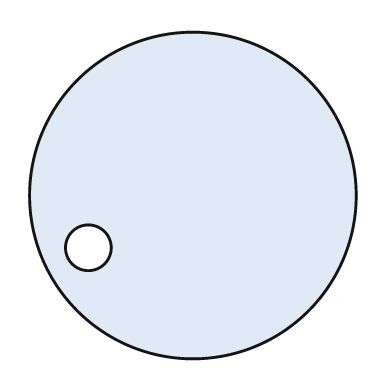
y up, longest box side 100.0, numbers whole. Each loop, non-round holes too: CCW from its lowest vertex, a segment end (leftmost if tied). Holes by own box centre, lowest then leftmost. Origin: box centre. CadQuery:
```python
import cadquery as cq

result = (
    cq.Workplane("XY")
    .moveTo(0.0, 0.0)
    .circle(50.0)
    .moveTo(-32.0, -16.0)
    .circle(7.0)
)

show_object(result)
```